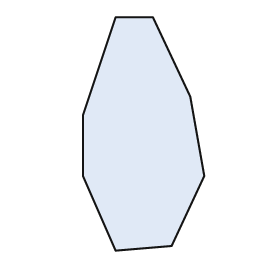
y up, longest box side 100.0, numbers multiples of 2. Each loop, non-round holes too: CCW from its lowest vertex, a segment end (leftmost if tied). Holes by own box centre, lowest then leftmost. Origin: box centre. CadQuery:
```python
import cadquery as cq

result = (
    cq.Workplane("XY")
    .moveTo(-12.0, -50.0)
    .lineTo(12.0, -48.0)
    .lineTo(26.0, -18.0)
    .lineTo(20.0, 16.0)
    .lineTo(4.0, 50.0)
    .lineTo(-12.0, 50.0)
    .lineTo(-26.0, 8.0)
    .lineTo(-26.0, -18.0)
    .close()
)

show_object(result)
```